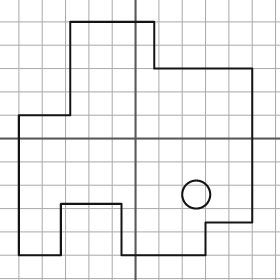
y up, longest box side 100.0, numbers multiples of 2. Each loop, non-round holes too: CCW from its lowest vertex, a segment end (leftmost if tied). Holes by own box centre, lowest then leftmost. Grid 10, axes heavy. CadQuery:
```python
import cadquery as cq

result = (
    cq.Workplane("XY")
    .moveTo(-50.0, -50.0)
    .lineTo(-32.0, -50.0)
    .lineTo(-32.0, -28.0)
    .lineTo(-6.0, -28.0)
    .lineTo(-6.0, -50.0)
    .lineTo(30.0, -50.0)
    .lineTo(30.0, -36.0)
    .lineTo(50.0, -36.0)
    .lineTo(50.0, 30.0)
    .lineTo(8.0, 30.0)
    .lineTo(8.0, 50.0)
    .lineTo(-28.0, 50.0)
    .lineTo(-28.0, 10.0)
    .lineTo(-50.0, 10.0)
    .close()
    .moveTo(26.0, -24.0)
    .circle(6.0)
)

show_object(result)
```